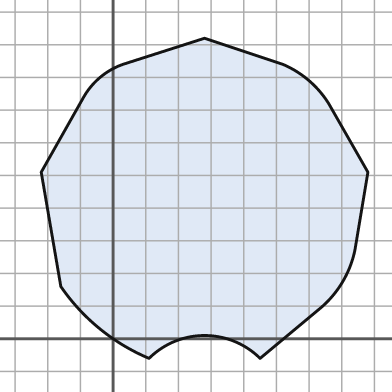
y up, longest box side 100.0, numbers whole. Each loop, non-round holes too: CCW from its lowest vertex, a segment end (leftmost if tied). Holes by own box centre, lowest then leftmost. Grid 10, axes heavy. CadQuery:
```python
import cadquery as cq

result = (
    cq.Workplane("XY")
    .moveTo(11.0, -6.0)
    .threePointArc((28.0, 1.0), (45.0, -6.0))
    .lineTo(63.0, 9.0)
    .threePointArc((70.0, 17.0), (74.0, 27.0))
    .lineTo(78.0, 51.0)
    .lineTo(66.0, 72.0)
    .threePointArc((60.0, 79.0), (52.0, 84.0))
    .lineTo(28.0, 92.0)
    .lineTo(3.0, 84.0)
    .threePointArc((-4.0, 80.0), (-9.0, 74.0))
    .lineTo(-22.0, 51.0)
    .lineTo(-16.0, 16.0)
    .threePointArc((-4.0, 3.0), (11.0, -6.0))
    .close()
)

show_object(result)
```